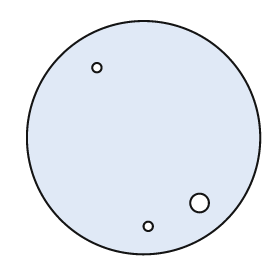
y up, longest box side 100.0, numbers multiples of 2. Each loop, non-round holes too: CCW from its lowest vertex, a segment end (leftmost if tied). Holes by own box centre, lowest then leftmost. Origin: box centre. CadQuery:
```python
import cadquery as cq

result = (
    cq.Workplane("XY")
    .moveTo(0.0, 0.0)
    .circle(50.0)
    .moveTo(2.0, -38.0)
    .circle(2.0)
    .moveTo(24.0, -28.0)
    .circle(4.0)
    .moveTo(-20.0, 30.0)
    .circle(2.0)
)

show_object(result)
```